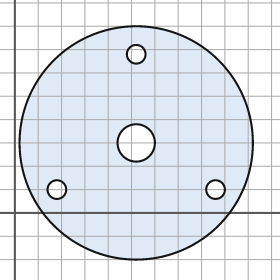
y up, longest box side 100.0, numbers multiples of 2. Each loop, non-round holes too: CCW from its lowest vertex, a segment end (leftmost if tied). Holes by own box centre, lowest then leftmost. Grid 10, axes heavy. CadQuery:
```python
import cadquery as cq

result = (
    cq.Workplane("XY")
    .moveTo(52.0, 30.0)
    .circle(50.0)
    .moveTo(18.0, 10.0)
    .circle(4.0)
    .moveTo(86.0, 10.0)
    .circle(4.0)
    .moveTo(52.0, 30.0)
    .circle(8.0)
    .moveTo(52.0, 68.0)
    .circle(4.0)
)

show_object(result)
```